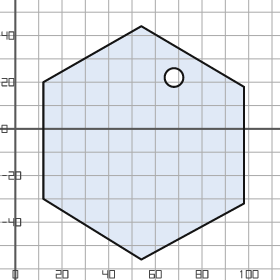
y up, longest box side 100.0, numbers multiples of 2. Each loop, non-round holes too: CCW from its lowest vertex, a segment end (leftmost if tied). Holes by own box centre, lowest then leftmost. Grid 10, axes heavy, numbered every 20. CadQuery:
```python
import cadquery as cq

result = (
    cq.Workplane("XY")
    .moveTo(54.0, -56.0)
    .lineTo(98.0, -32.0)
    .lineTo(98.0, 18.0)
    .lineTo(54.0, 44.0)
    .lineTo(12.0, 20.0)
    .lineTo(12.0, -30.0)
    .close()
    .moveTo(68.0, 22.0)
    .circle(4.0)
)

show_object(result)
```